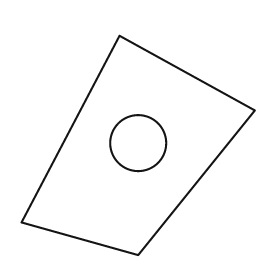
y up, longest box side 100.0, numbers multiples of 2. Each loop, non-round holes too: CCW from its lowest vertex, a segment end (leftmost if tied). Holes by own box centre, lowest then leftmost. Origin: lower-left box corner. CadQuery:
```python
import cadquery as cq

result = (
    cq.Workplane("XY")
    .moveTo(50.0, 0.0)
    .lineTo(100.0, 62.0)
    .lineTo(42.0, 94.0)
    .lineTo(0.0, 14.0)
    .close()
    .moveTo(50.0, 48.0)
    .circle(12.0)
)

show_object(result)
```